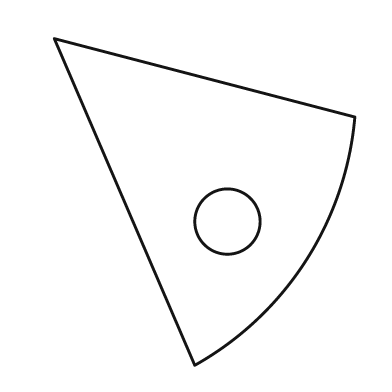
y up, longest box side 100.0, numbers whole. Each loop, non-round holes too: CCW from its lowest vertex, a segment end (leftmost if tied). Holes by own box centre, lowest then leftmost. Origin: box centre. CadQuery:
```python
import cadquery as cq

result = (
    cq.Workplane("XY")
    .moveTo(-3.0, -50.0)
    .threePointArc((31.0, -18.0), (46.0, 26.0))
    .lineTo(-46.0, 50.0)
    .close()
    .moveTo(7.0, -6.0)
    .circle(10.0)
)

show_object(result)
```